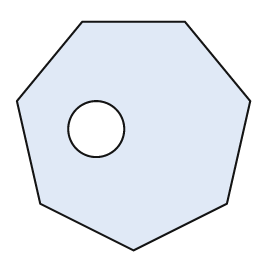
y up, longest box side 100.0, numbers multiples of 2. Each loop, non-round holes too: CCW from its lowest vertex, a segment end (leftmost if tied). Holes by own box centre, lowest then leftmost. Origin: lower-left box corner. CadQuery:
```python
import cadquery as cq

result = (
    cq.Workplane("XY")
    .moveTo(50.0, 0.0)
    .lineTo(90.0, 20.0)
    .lineTo(100.0, 64.0)
    .lineTo(72.0, 98.0)
    .lineTo(28.0, 98.0)
    .lineTo(0.0, 64.0)
    .lineTo(10.0, 20.0)
    .close()
    .moveTo(34.0, 52.0)
    .circle(12.0)
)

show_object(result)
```